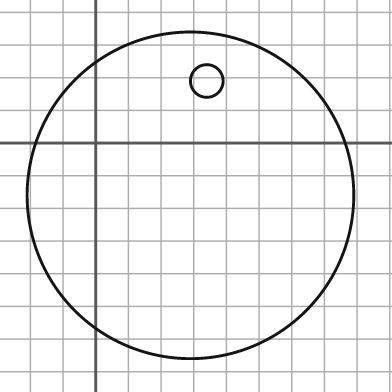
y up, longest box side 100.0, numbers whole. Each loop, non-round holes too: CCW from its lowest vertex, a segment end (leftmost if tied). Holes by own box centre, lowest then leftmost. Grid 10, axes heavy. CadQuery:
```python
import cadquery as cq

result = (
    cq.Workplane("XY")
    .moveTo(29.0, -16.0)
    .circle(50.0)
    .moveTo(34.0, 19.0)
    .circle(5.0)
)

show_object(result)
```